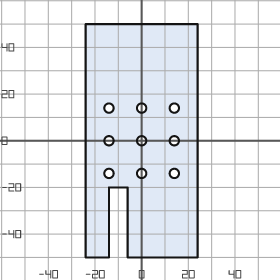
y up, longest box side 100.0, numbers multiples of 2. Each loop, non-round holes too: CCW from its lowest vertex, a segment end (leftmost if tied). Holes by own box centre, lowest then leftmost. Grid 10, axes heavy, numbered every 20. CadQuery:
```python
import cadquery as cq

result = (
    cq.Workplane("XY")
    .moveTo(-24.0, -50.0)
    .lineTo(-14.0, -50.0)
    .lineTo(-14.0, -20.0)
    .lineTo(-6.0, -20.0)
    .lineTo(-6.0, -50.0)
    .lineTo(24.0, -50.0)
    .lineTo(24.0, 50.0)
    .lineTo(-24.0, 50.0)
    .close()
    .moveTo(-14.0, -14.0)
    .circle(2.0)
    .moveTo(0.0, -14.0)
    .circle(2.0)
    .moveTo(14.0, -14.0)
    .circle(2.0)
    .moveTo(-14.0, 0.0)
    .circle(2.0)
    .moveTo(0.0, 0.0)
    .circle(2.0)
    .moveTo(14.0, 0.0)
    .circle(2.0)
    .moveTo(-14.0, 14.0)
    .circle(2.0)
    .moveTo(0.0, 14.0)
    .circle(2.0)
    .moveTo(14.0, 14.0)
    .circle(2.0)
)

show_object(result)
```